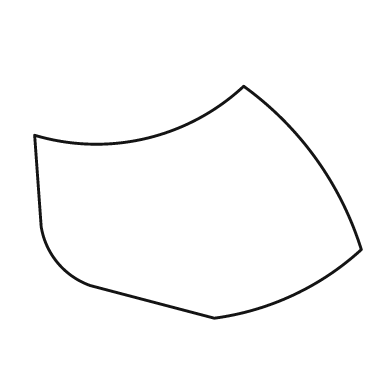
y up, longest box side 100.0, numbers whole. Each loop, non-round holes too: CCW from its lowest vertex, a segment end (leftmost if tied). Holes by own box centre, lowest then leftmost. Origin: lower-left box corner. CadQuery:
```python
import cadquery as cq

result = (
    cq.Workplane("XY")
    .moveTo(55.0, 0.0)
    .threePointArc((79.0, 7.0), (100.0, 21.0))
    .threePointArc((86.0, 49.0), (64.0, 71.0))
    .threePointArc((34.0, 55.0), (0.0, 56.0))
    .lineTo(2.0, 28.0)
    .threePointArc((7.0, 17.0), (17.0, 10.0))
    .close()
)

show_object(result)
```